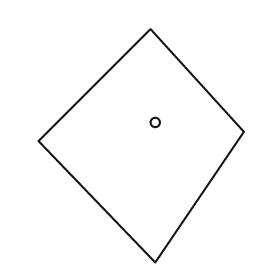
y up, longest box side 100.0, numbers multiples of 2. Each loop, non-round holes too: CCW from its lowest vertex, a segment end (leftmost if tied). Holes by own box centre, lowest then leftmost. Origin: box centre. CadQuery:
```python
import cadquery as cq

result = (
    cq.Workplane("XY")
    .moveTo(6.0, -50.0)
    .lineTo(44.0, 6.0)
    .lineTo(4.0, 50.0)
    .lineTo(-44.0, 2.0)
    .close()
    .moveTo(6.0, 10.0)
    .circle(2.0)
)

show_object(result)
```